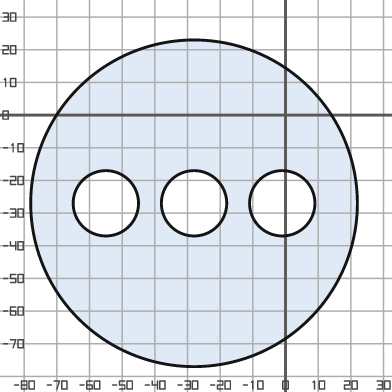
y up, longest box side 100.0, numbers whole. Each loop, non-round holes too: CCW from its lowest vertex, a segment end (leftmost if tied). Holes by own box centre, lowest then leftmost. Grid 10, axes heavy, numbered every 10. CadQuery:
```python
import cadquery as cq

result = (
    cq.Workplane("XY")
    .moveTo(-28.0, -27.0)
    .circle(50.0)
    .moveTo(-55.0, -27.0)
    .circle(10.0)
    .moveTo(-28.0, -27.0)
    .circle(10.0)
    .moveTo(-1.0, -27.0)
    .circle(10.0)
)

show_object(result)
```